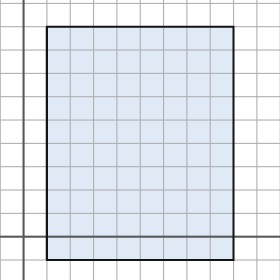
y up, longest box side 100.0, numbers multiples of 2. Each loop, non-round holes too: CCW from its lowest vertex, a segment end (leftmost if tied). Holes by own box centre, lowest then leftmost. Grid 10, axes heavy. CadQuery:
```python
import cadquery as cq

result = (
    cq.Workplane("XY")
    .moveTo(10.0, -10.0)
    .lineTo(90.0, -10.0)
    .lineTo(90.0, 90.0)
    .lineTo(10.0, 90.0)
    .close()
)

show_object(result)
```